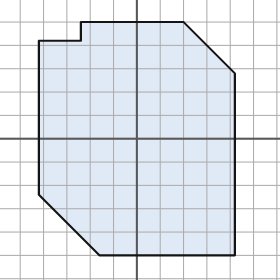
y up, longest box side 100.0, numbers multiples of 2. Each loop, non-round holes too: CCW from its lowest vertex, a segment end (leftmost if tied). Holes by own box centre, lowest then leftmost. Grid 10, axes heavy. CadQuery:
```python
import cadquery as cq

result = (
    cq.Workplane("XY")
    .moveTo(-16.0, -50.0)
    .lineTo(42.0, -50.0)
    .lineTo(42.0, 28.0)
    .lineTo(20.0, 50.0)
    .lineTo(-24.0, 50.0)
    .lineTo(-24.0, 42.0)
    .lineTo(-42.0, 42.0)
    .lineTo(-42.0, -24.0)
    .close()
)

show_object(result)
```